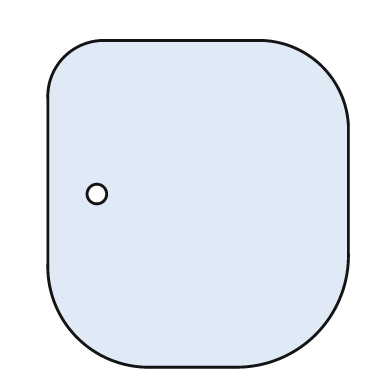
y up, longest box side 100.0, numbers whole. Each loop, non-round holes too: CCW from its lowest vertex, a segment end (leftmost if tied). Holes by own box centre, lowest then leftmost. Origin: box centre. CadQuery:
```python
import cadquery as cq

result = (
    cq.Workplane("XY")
    .moveTo(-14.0, -50.0)
    .lineTo(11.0, -50.0)
    .threePointArc((36.0, -40.0), (46.0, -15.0))
    .lineTo(46.0, 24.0)
    .threePointArc((38.0, 42.0), (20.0, 50.0))
    .lineTo(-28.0, 50.0)
    .threePointArc((-41.0, 45.0), (-46.0, 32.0))
    .lineTo(-46.0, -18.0)
    .threePointArc((-37.0, -41.0), (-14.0, -50.0))
    .close()
    .moveTo(-31.0, 3.0)
    .circle(3.0)
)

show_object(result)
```